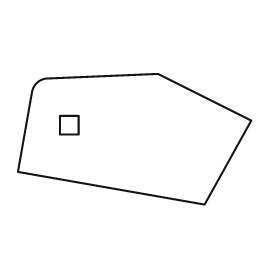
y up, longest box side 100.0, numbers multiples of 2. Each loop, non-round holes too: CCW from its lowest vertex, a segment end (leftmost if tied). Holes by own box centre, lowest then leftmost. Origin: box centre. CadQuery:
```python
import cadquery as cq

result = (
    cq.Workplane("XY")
    .moveTo(30.0, -28.0)
    .lineTo(50.0, 8.0)
    .lineTo(10.0, 28.0)
    .lineTo(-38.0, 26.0)
    .threePointArc((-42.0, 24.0), (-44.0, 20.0))
    .lineTo(-50.0, -14.0)
    .close()
    .moveTo(-32.0, 2.0)
    .lineTo(-24.0, 2.0)
    .lineTo(-24.0, 10.0)
    .lineTo(-32.0, 10.0)
    .close()
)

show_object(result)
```